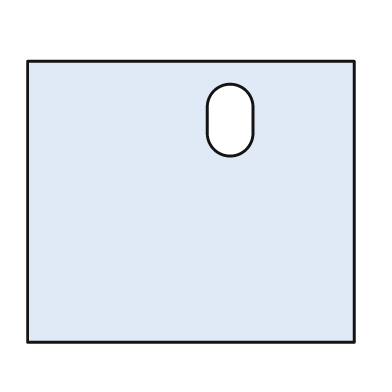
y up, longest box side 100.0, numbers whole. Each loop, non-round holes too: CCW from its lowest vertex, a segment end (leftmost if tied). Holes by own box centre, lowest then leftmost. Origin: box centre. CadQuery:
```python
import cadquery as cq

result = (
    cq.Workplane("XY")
    .moveTo(-50.0, -43.0)
    .lineTo(50.0, -43.0)
    .lineTo(50.0, 43.0)
    .lineTo(-50.0, 43.0)
    .close()
    .moveTo(5.0, 21.0)
    .threePointArc((12.0, 14.0), (19.0, 21.0))
    .lineTo(19.0, 29.0)
    .threePointArc((12.0, 36.0), (5.0, 29.0))
    .close()
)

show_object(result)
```